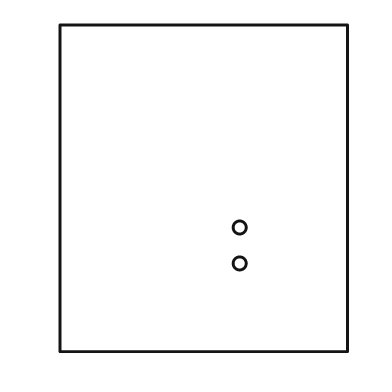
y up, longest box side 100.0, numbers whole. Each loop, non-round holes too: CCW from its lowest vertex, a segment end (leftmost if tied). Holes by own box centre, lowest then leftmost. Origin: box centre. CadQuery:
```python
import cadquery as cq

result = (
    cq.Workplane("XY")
    .moveTo(-44.0, -50.0)
    .lineTo(44.0, -50.0)
    .lineTo(44.0, 50.0)
    .lineTo(-44.0, 50.0)
    .close()
    .moveTo(11.0, -23.0)
    .circle(2.0)
    .moveTo(11.0, -12.0)
    .circle(2.0)
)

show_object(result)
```